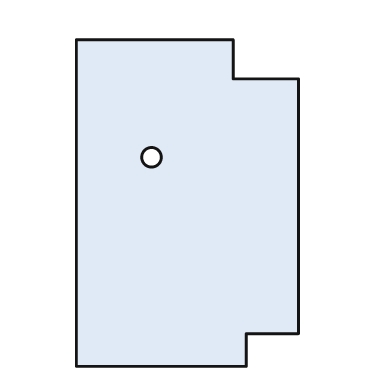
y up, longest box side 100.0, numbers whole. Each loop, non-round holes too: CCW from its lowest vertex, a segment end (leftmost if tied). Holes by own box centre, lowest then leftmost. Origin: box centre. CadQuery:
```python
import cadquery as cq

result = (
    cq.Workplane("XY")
    .moveTo(-34.0, -50.0)
    .lineTo(18.0, -50.0)
    .lineTo(18.0, -40.0)
    .lineTo(34.0, -40.0)
    .lineTo(34.0, 38.0)
    .lineTo(14.0, 38.0)
    .lineTo(14.0, 50.0)
    .lineTo(-34.0, 50.0)
    .close()
    .moveTo(-11.0, 14.0)
    .circle(3.0)
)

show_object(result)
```